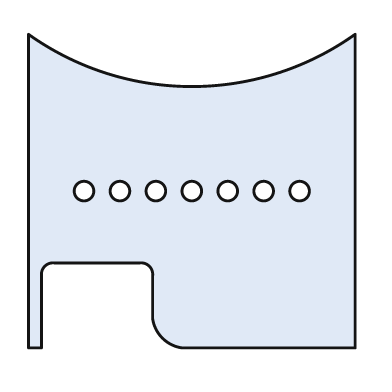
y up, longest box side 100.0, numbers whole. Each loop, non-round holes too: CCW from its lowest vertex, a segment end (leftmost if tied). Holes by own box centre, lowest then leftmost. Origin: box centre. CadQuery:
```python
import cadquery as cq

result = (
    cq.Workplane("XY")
    .moveTo(-50.0, -48.0)
    .lineTo(-46.0, -48.0)
    .lineTo(-46.0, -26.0)
    .threePointArc((-45.0, -23.0), (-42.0, -22.0))
    .lineTo(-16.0, -22.0)
    .threePointArc((-13.0, -23.0), (-12.0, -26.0))
    .lineTo(-12.0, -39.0)
    .threePointArc((-9.0, -45.0), (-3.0, -48.0))
    .lineTo(50.0, -48.0)
    .lineTo(50.0, 48.0)
    .threePointArc((0.0, 32.0), (-50.0, 48.0))
    .close()
    .moveTo(-33.0, 0.0)
    .circle(3.0)
    .moveTo(-22.0, 0.0)
    .circle(3.0)
    .moveTo(-11.0, 0.0)
    .circle(3.0)
    .moveTo(0.0, 0.0)
    .circle(3.0)
    .moveTo(11.0, 0.0)
    .circle(3.0)
    .moveTo(22.0, 0.0)
    .circle(3.0)
    .moveTo(33.0, 0.0)
    .circle(3.0)
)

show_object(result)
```